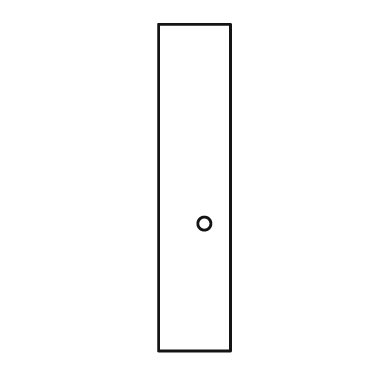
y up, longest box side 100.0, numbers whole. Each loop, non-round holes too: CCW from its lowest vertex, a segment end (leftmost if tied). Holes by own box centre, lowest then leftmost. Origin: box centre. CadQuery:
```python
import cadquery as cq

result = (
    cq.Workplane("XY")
    .moveTo(-11.0, -50.0)
    .lineTo(11.0, -50.0)
    .lineTo(11.0, 50.0)
    .lineTo(-11.0, 50.0)
    .close()
    .moveTo(3.0, -11.0)
    .circle(2.0)
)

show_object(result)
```